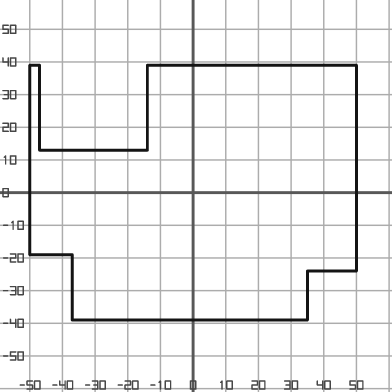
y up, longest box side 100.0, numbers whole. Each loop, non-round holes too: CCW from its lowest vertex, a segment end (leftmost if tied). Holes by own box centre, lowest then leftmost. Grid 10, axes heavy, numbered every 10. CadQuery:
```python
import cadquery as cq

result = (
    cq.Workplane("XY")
    .moveTo(-37.0, -39.0)
    .lineTo(35.0, -39.0)
    .lineTo(35.0, -24.0)
    .lineTo(50.0, -24.0)
    .lineTo(50.0, 39.0)
    .lineTo(-14.0, 39.0)
    .lineTo(-14.0, 13.0)
    .lineTo(-47.0, 13.0)
    .lineTo(-47.0, 39.0)
    .lineTo(-50.0, 39.0)
    .lineTo(-50.0, -19.0)
    .lineTo(-37.0, -19.0)
    .close()
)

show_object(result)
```